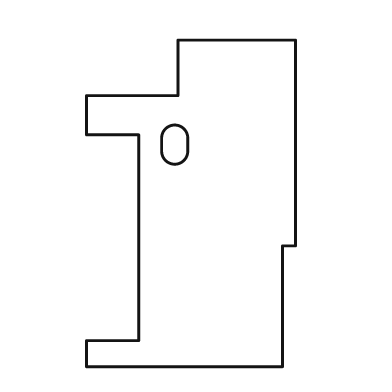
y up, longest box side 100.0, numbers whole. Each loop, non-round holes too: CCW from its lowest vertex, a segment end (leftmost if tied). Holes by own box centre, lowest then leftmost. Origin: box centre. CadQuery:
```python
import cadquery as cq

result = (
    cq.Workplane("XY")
    .moveTo(-32.0, -50.0)
    .lineTo(28.0, -50.0)
    .lineTo(28.0, -13.0)
    .lineTo(32.0, -13.0)
    .lineTo(32.0, 50.0)
    .lineTo(-4.0, 50.0)
    .lineTo(-4.0, 33.0)
    .lineTo(-32.0, 33.0)
    .lineTo(-32.0, 21.0)
    .lineTo(-16.0, 21.0)
    .lineTo(-16.0, -42.0)
    .lineTo(-32.0, -42.0)
    .close()
    .moveTo(-9.0, 16.0)
    .threePointArc((-5.0, 12.0), (-1.0, 16.0))
    .lineTo(-1.0, 20.0)
    .threePointArc((-5.0, 24.0), (-9.0, 20.0))
    .close()
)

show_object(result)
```